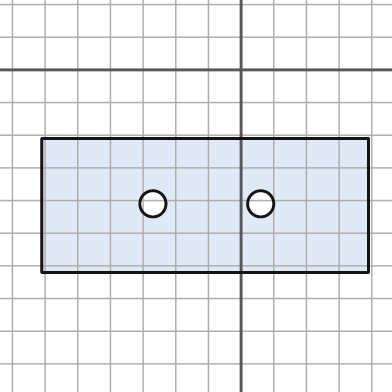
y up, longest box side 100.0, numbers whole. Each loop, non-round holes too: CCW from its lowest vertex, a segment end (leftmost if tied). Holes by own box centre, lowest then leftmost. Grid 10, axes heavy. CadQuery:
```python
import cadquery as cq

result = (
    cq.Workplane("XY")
    .moveTo(-61.0, -62.0)
    .lineTo(39.0, -62.0)
    .lineTo(39.0, -21.0)
    .lineTo(-61.0, -21.0)
    .close()
    .moveTo(-27.0, -41.0)
    .circle(4.0)
    .moveTo(6.0, -41.0)
    .circle(4.0)
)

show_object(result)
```